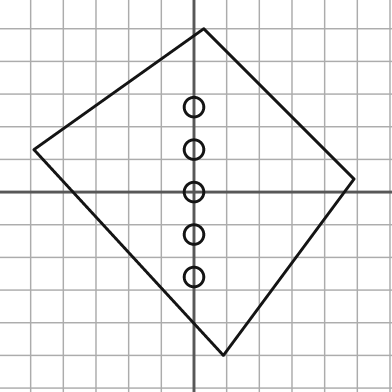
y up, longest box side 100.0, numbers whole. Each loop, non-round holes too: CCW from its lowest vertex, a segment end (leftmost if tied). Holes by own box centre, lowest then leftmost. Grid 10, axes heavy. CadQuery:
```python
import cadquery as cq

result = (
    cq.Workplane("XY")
    .moveTo(9.0, -50.0)
    .lineTo(49.0, 4.0)
    .lineTo(3.0, 50.0)
    .lineTo(-49.0, 13.0)
    .close()
    .moveTo(0.0, -26.0)
    .circle(3.0)
    .moveTo(0.0, -13.0)
    .circle(3.0)
    .moveTo(0.0, 0.0)
    .circle(3.0)
    .moveTo(0.0, 13.0)
    .circle(3.0)
    .moveTo(0.0, 26.0)
    .circle(3.0)
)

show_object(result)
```